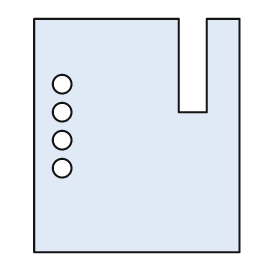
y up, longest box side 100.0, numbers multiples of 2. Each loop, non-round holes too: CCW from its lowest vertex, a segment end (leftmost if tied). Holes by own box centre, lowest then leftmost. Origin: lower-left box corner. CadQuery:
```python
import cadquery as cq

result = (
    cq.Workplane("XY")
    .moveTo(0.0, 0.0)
    .lineTo(88.0, 0.0)
    .lineTo(88.0, 100.0)
    .lineTo(74.0, 100.0)
    .lineTo(74.0, 60.0)
    .lineTo(62.0, 60.0)
    .lineTo(62.0, 100.0)
    .lineTo(0.0, 100.0)
    .close()
    .moveTo(12.0, 36.0)
    .circle(4.0)
    .moveTo(12.0, 48.0)
    .circle(4.0)
    .moveTo(12.0, 60.0)
    .circle(4.0)
    .moveTo(12.0, 72.0)
    .circle(4.0)
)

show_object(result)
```